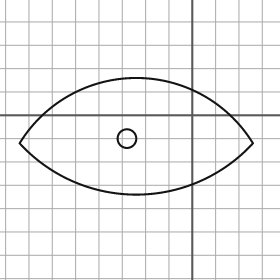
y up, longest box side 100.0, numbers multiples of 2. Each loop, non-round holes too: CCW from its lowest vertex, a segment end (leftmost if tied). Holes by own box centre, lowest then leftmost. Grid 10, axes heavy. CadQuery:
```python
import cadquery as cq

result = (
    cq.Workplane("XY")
    .moveTo(-74.0, -12.0)
    .threePointArc((-24.0, -34.0), (26.0, -12.0))
    .threePointArc((-24.0, 16.0), (-74.0, -12.0))
    .close()
    .moveTo(-28.0, -10.0)
    .circle(4.0)
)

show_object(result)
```